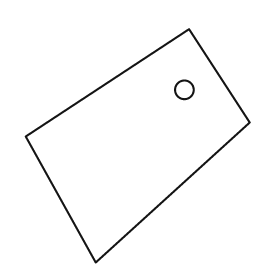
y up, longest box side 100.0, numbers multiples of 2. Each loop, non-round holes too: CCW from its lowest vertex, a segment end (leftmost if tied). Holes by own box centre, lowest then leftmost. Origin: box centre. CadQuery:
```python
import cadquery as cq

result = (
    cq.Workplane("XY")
    .moveTo(-18.0, -50.0)
    .lineTo(48.0, 10.0)
    .lineTo(22.0, 50.0)
    .lineTo(-48.0, 4.0)
    .close()
    .moveTo(20.0, 24.0)
    .circle(4.0)
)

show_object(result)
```